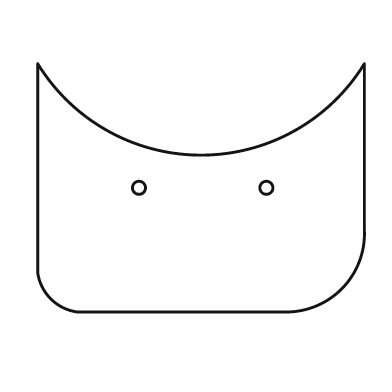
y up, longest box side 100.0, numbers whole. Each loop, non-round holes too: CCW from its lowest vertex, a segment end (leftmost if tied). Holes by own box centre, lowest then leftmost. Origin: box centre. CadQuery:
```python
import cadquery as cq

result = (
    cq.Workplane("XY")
    .moveTo(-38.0, -38.0)
    .lineTo(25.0, -38.0)
    .threePointArc((43.0, -31.0), (50.0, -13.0))
    .lineTo(50.0, 38.0)
    .threePointArc((0.0, 10.0), (-50.0, 38.0))
    .lineTo(-50.0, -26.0)
    .threePointArc((-46.0, -34.0), (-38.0, -38.0))
    .close()
    .moveTo(-19.0, 0.0)
    .circle(2.0)
    .moveTo(20.0, 0.0)
    .circle(2.0)
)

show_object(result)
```